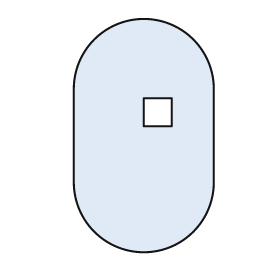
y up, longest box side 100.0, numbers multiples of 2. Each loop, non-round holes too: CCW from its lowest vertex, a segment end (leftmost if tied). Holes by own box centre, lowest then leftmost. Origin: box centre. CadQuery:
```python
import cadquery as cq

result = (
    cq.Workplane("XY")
    .moveTo(-30.0, -20.0)
    .threePointArc((0.0, -50.0), (30.0, -20.0))
    .lineTo(30.0, 20.0)
    .threePointArc((0.0, 50.0), (-30.0, 20.0))
    .close()
    .moveTo(0.0, 4.0)
    .lineTo(12.0, 4.0)
    .lineTo(12.0, 16.0)
    .lineTo(0.0, 16.0)
    .close()
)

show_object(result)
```